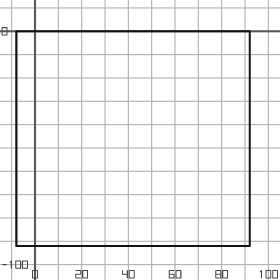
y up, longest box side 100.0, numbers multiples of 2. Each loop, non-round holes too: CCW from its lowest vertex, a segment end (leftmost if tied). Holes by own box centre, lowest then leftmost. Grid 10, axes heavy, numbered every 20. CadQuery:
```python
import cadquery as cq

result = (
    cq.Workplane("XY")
    .moveTo(-8.0, -92.0)
    .lineTo(92.0, -92.0)
    .lineTo(92.0, 0.0)
    .lineTo(-8.0, 0.0)
    .close()
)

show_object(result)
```